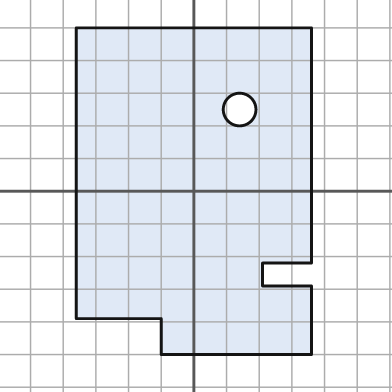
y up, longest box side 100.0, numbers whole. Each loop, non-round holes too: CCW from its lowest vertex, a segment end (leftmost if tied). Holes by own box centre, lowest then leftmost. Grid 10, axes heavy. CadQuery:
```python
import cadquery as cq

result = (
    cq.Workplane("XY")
    .moveTo(-10.0, -50.0)
    .lineTo(36.0, -50.0)
    .lineTo(36.0, -29.0)
    .lineTo(21.0, -29.0)
    .lineTo(21.0, -22.0)
    .lineTo(36.0, -22.0)
    .lineTo(36.0, 50.0)
    .lineTo(-36.0, 50.0)
    .lineTo(-36.0, -39.0)
    .lineTo(-10.0, -39.0)
    .close()
    .moveTo(14.0, 25.0)
    .circle(5.0)
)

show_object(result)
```